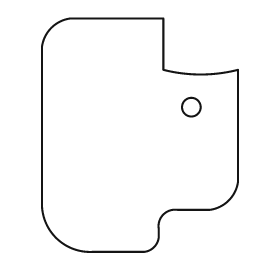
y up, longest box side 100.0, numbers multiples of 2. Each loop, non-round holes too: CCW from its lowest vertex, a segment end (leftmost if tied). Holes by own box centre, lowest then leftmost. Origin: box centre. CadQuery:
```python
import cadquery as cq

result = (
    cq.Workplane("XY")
    .moveTo(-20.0, -50.0)
    .lineTo(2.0, -50.0)
    .threePointArc((6.0, -48.0), (8.0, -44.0))
    .lineTo(8.0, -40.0)
    .threePointArc((10.0, -34.0), (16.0, -32.0))
    .lineTo(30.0, -32.0)
    .threePointArc((38.0, -28.0), (42.0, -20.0))
    .lineTo(42.0, 28.0)
    .threePointArc((26.0, 26.0), (10.0, 28.0))
    .lineTo(10.0, 50.0)
    .lineTo(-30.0, 50.0)
    .threePointArc((-38.0, 46.0), (-42.0, 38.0))
    .lineTo(-42.0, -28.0)
    .threePointArc((-36.0, -44.0), (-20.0, -50.0))
    .close()
    .moveTo(22.0, 12.0)
    .circle(4.0)
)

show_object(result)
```